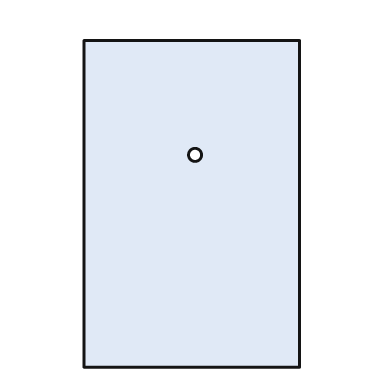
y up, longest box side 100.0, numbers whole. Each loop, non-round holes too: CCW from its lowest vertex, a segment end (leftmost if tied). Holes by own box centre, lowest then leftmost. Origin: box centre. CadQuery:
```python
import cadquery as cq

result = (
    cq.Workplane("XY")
    .moveTo(-33.0, -50.0)
    .lineTo(33.0, -50.0)
    .lineTo(33.0, 50.0)
    .lineTo(-33.0, 50.0)
    .close()
    .moveTo(1.0, 15.0)
    .circle(2.0)
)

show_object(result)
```